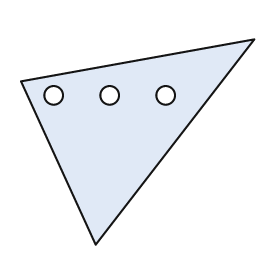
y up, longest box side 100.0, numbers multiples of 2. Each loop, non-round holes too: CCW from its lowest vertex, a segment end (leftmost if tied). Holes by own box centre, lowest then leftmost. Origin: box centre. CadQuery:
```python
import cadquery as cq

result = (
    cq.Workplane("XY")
    .moveTo(-18.0, -44.0)
    .lineTo(50.0, 44.0)
    .lineTo(-50.0, 26.0)
    .close()
    .moveTo(-36.0, 20.0)
    .circle(4.0)
    .moveTo(-12.0, 20.0)
    .circle(4.0)
    .moveTo(12.0, 20.0)
    .circle(4.0)
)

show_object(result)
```